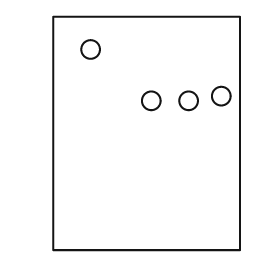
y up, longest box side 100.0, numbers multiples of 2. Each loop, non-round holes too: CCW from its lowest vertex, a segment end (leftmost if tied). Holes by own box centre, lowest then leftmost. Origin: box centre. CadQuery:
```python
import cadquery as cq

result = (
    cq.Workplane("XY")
    .moveTo(-40.0, -50.0)
    .lineTo(40.0, -50.0)
    .lineTo(40.0, 50.0)
    .lineTo(-40.0, 50.0)
    .close()
    .moveTo(2.0, 14.0)
    .circle(4.0)
    .moveTo(18.0, 14.0)
    .circle(4.0)
    .moveTo(32.0, 16.0)
    .circle(4.0)
    .moveTo(-24.0, 36.0)
    .circle(4.0)
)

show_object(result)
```